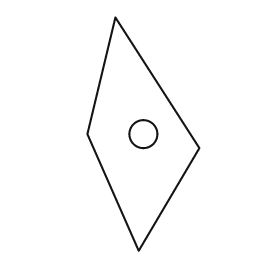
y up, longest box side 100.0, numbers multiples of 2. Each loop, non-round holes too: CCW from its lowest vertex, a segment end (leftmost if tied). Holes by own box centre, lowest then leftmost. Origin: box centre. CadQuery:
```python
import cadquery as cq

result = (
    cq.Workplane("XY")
    .moveTo(-2.0, -50.0)
    .lineTo(24.0, -6.0)
    .lineTo(-12.0, 50.0)
    .lineTo(-24.0, 0.0)
    .close()
    .moveTo(0.0, 0.0)
    .circle(6.0)
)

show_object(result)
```